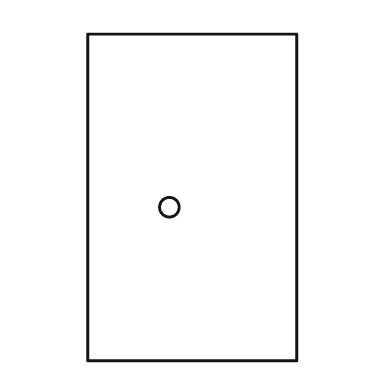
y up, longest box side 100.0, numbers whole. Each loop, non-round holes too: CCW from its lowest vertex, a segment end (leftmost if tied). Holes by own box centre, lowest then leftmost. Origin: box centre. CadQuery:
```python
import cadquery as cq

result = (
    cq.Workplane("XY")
    .moveTo(-32.0, -50.0)
    .lineTo(32.0, -50.0)
    .lineTo(32.0, 50.0)
    .lineTo(-32.0, 50.0)
    .close()
    .moveTo(-7.0, -3.0)
    .circle(3.0)
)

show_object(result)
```